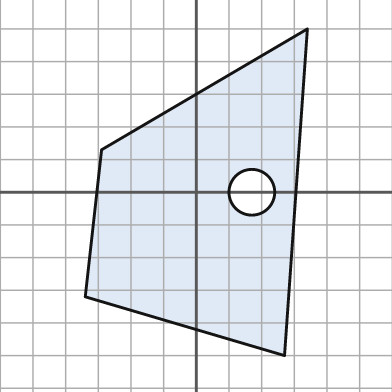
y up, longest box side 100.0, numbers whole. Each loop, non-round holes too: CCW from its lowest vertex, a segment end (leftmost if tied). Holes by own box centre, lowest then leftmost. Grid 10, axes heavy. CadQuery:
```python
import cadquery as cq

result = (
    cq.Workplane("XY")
    .moveTo(27.0, -50.0)
    .lineTo(34.0, 50.0)
    .lineTo(-29.0, 13.0)
    .lineTo(-34.0, -32.0)
    .close()
    .moveTo(17.0, 0.0)
    .circle(7.0)
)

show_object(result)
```